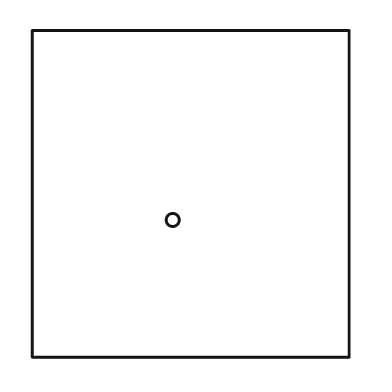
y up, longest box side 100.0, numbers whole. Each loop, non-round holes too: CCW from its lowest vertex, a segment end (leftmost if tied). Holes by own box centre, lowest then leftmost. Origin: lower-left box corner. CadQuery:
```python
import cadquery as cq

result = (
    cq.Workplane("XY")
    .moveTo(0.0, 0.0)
    .lineTo(97.0, 0.0)
    .lineTo(97.0, 100.0)
    .lineTo(0.0, 100.0)
    .close()
    .moveTo(43.0, 42.0)
    .circle(2.0)
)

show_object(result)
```